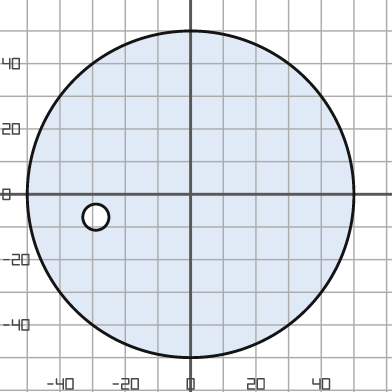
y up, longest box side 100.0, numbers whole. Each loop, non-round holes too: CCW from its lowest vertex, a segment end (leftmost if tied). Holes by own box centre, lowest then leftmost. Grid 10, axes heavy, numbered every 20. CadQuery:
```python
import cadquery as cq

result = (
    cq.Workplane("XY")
    .moveTo(0.0, 0.0)
    .circle(50.0)
    .moveTo(-29.0, -7.0)
    .circle(4.0)
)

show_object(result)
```